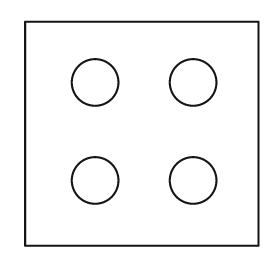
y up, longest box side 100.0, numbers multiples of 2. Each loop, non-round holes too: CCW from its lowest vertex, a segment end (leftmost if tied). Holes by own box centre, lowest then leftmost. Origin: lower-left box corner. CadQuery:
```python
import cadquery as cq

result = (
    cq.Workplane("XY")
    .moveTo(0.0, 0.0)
    .lineTo(100.0, 0.0)
    .lineTo(100.0, 96.0)
    .lineTo(0.0, 96.0)
    .close()
    .moveTo(30.0, 28.0)
    .circle(10.0)
    .moveTo(72.0, 28.0)
    .circle(10.0)
    .moveTo(30.0, 70.0)
    .circle(10.0)
    .moveTo(72.0, 70.0)
    .circle(10.0)
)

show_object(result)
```